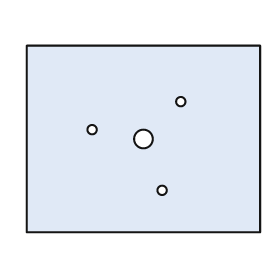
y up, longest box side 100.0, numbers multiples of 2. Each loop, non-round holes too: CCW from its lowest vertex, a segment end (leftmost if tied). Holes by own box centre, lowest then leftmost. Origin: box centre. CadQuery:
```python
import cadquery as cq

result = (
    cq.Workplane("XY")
    .moveTo(-50.0, -40.0)
    .lineTo(50.0, -40.0)
    .lineTo(50.0, 40.0)
    .lineTo(-50.0, 40.0)
    .close()
    .moveTo(8.0, -22.0)
    .circle(2.0)
    .moveTo(0.0, 0.0)
    .circle(4.0)
    .moveTo(-22.0, 4.0)
    .circle(2.0)
    .moveTo(16.0, 16.0)
    .circle(2.0)
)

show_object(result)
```